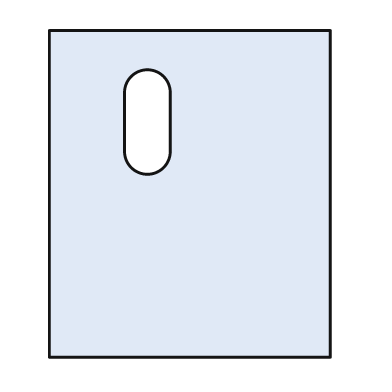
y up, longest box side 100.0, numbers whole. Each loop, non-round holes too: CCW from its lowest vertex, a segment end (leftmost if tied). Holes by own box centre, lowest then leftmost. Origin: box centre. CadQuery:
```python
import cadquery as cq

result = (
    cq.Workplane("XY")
    .moveTo(-43.0, -50.0)
    .lineTo(43.0, -50.0)
    .lineTo(43.0, 50.0)
    .lineTo(-43.0, 50.0)
    .close()
    .moveTo(-20.0, 13.0)
    .threePointArc((-13.0, 6.0), (-6.0, 13.0))
    .lineTo(-6.0, 31.0)
    .threePointArc((-13.0, 38.0), (-20.0, 31.0))
    .close()
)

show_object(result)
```